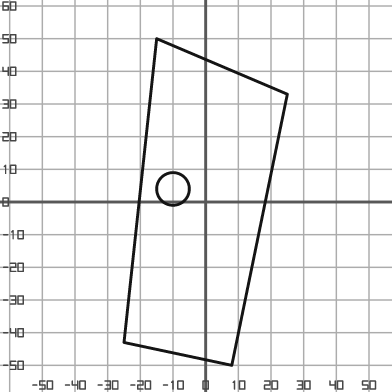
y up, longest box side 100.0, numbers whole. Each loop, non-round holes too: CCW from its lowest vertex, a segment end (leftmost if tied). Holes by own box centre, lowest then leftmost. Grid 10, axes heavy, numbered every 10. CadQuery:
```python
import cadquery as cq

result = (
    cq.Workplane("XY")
    .moveTo(8.0, -50.0)
    .lineTo(25.0, 33.0)
    .lineTo(-15.0, 50.0)
    .lineTo(-25.0, -43.0)
    .close()
    .moveTo(-10.0, 4.0)
    .circle(5.0)
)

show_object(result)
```